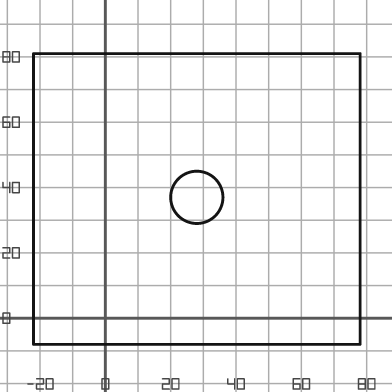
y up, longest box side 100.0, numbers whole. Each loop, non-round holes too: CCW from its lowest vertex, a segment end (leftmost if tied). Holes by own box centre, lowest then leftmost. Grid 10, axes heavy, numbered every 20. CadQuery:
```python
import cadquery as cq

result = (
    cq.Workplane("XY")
    .moveTo(-22.0, -8.0)
    .lineTo(78.0, -8.0)
    .lineTo(78.0, 81.0)
    .lineTo(-22.0, 81.0)
    .close()
    .moveTo(28.0, 37.0)
    .circle(8.0)
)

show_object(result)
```